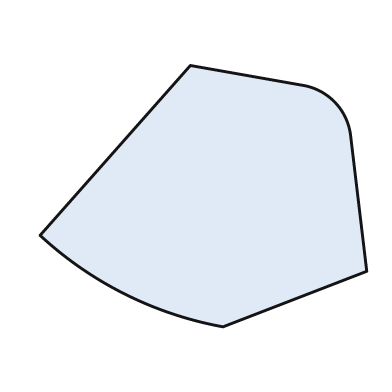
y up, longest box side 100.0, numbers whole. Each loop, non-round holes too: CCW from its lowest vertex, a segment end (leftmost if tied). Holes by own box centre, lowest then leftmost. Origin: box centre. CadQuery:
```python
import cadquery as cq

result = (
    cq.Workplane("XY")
    .moveTo(6.0, -40.0)
    .lineTo(50.0, -23.0)
    .lineTo(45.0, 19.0)
    .threePointArc((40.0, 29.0), (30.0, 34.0))
    .lineTo(-4.0, 40.0)
    .lineTo(-50.0, -12.0)
    .threePointArc((-24.0, -30.0), (6.0, -40.0))
    .close()
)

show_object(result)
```